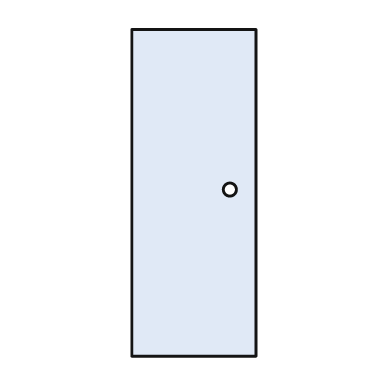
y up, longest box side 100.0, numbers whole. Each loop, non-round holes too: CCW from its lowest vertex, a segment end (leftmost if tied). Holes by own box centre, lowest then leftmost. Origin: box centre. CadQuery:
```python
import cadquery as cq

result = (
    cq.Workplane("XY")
    .moveTo(-19.0, -50.0)
    .lineTo(19.0, -50.0)
    .lineTo(19.0, 50.0)
    .lineTo(-19.0, 50.0)
    .close()
    .moveTo(11.0, 1.0)
    .circle(2.0)
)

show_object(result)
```